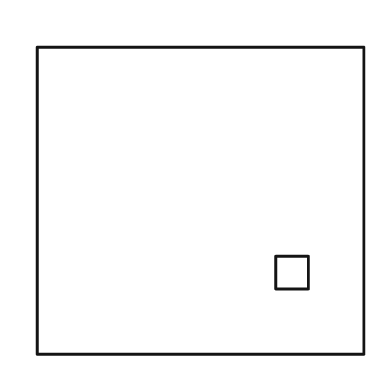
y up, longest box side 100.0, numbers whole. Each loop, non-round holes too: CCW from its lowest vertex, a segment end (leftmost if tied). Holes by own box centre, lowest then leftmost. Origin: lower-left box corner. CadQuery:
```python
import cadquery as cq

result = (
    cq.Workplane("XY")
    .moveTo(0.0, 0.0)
    .lineTo(100.0, 0.0)
    .lineTo(100.0, 94.0)
    .lineTo(0.0, 94.0)
    .close()
    .moveTo(73.0, 20.0)
    .lineTo(83.0, 20.0)
    .lineTo(83.0, 30.0)
    .lineTo(73.0, 30.0)
    .close()
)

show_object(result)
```